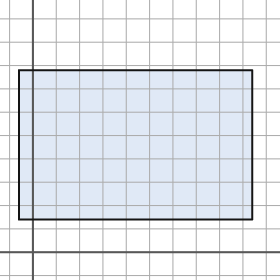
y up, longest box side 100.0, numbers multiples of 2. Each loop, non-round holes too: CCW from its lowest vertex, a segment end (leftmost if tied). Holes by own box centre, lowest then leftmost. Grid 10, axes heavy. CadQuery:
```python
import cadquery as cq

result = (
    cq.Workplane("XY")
    .moveTo(-6.0, 14.0)
    .lineTo(94.0, 14.0)
    .lineTo(94.0, 78.0)
    .lineTo(-6.0, 78.0)
    .close()
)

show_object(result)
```